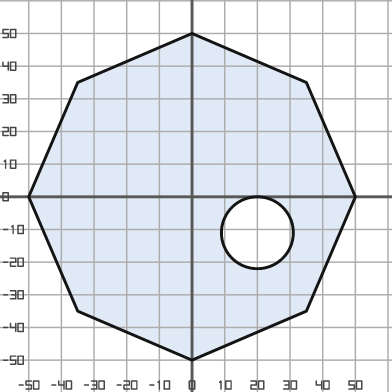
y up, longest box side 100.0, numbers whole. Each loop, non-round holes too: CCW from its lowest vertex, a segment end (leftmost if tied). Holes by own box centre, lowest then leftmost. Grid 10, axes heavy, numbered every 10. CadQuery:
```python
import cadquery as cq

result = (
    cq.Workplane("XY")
    .moveTo(0.0, -50.0)
    .lineTo(35.0, -35.0)
    .lineTo(50.0, 0.0)
    .lineTo(35.0, 35.0)
    .lineTo(0.0, 50.0)
    .lineTo(-35.0, 35.0)
    .lineTo(-50.0, 0.0)
    .lineTo(-35.0, -35.0)
    .close()
    .moveTo(20.0, -11.0)
    .circle(11.0)
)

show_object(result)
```